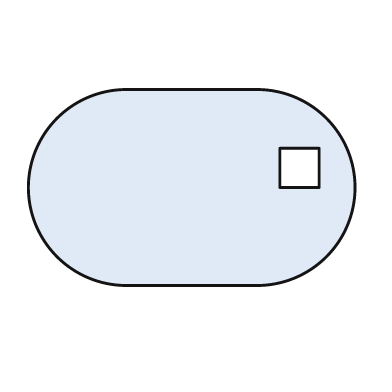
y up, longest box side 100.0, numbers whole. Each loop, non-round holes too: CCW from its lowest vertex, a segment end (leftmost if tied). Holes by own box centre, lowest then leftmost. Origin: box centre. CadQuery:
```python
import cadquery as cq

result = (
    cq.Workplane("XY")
    .moveTo(-20.0, -30.0)
    .lineTo(20.0, -30.0)
    .threePointArc((50.0, 0.0), (20.0, 30.0))
    .lineTo(-20.0, 30.0)
    .threePointArc((-50.0, 0.0), (-20.0, -30.0))
    .close()
    .moveTo(27.0, 0.0)
    .lineTo(39.0, 0.0)
    .lineTo(39.0, 12.0)
    .lineTo(27.0, 12.0)
    .close()
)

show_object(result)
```